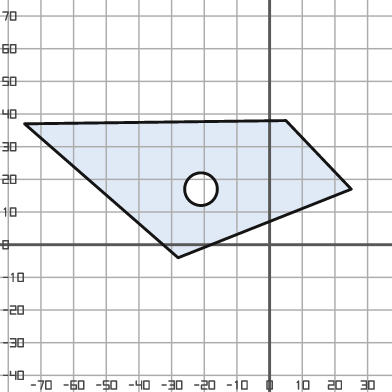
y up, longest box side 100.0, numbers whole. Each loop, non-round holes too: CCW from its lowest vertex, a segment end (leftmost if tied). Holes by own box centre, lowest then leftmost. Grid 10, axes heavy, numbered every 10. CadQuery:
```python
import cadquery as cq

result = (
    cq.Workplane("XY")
    .moveTo(-28.0, -4.0)
    .lineTo(25.0, 17.0)
    .lineTo(5.0, 38.0)
    .lineTo(-75.0, 37.0)
    .close()
    .moveTo(-21.0, 17.0)
    .circle(5.0)
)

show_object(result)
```